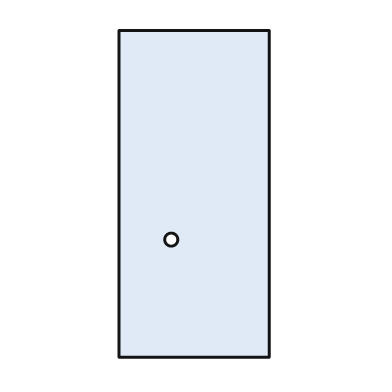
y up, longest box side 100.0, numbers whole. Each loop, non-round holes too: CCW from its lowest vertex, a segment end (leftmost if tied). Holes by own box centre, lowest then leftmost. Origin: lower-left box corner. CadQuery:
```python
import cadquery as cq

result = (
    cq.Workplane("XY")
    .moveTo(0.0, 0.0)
    .lineTo(46.0, 0.0)
    .lineTo(46.0, 100.0)
    .lineTo(0.0, 100.0)
    .close()
    .moveTo(16.0, 36.0)
    .circle(2.0)
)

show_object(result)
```